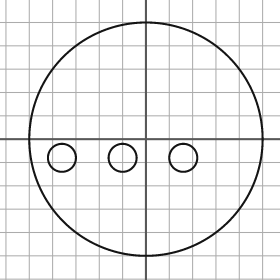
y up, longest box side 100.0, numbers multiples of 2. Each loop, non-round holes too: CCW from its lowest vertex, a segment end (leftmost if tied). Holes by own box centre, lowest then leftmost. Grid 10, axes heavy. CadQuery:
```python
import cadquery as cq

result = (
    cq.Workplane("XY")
    .moveTo(0.0, 0.0)
    .circle(50.0)
    .moveTo(-36.0, -8.0)
    .circle(6.0)
    .moveTo(-10.0, -8.0)
    .circle(6.0)
    .moveTo(16.0, -8.0)
    .circle(6.0)
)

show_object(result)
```